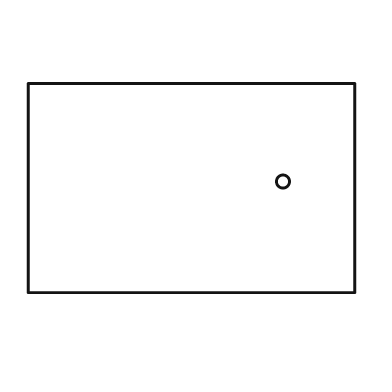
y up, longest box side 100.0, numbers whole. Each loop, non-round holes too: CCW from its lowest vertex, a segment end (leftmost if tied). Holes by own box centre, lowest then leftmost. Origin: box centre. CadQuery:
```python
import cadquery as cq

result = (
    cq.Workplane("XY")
    .moveTo(-50.0, -32.0)
    .lineTo(50.0, -32.0)
    .lineTo(50.0, 32.0)
    .lineTo(-50.0, 32.0)
    .close()
    .moveTo(28.0, 2.0)
    .circle(2.0)
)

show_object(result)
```